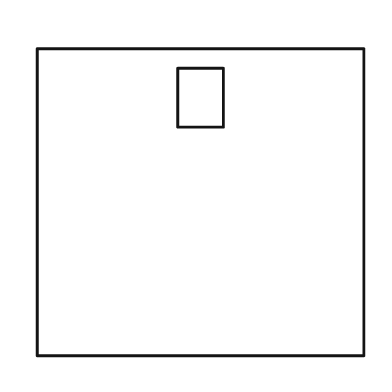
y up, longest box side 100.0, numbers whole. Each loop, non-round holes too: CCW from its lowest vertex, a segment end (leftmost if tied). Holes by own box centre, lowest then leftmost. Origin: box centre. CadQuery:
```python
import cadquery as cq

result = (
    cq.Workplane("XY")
    .moveTo(-50.0, -47.0)
    .lineTo(50.0, -47.0)
    .lineTo(50.0, 47.0)
    .lineTo(-50.0, 47.0)
    .close()
    .moveTo(-7.0, 23.0)
    .lineTo(7.0, 23.0)
    .lineTo(7.0, 41.0)
    .lineTo(-7.0, 41.0)
    .close()
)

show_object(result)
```